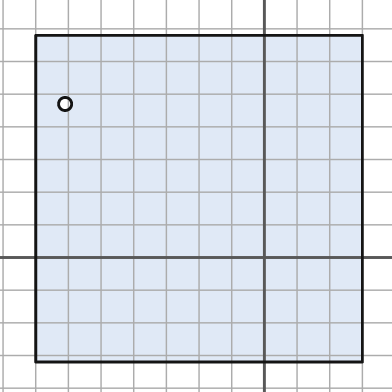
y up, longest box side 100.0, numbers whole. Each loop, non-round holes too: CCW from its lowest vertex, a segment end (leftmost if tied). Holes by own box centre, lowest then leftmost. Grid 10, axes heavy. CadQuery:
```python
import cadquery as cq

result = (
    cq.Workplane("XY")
    .moveTo(-70.0, -32.0)
    .lineTo(30.0, -32.0)
    .lineTo(30.0, 68.0)
    .lineTo(-70.0, 68.0)
    .close()
    .moveTo(-61.0, 47.0)
    .circle(2.0)
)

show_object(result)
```